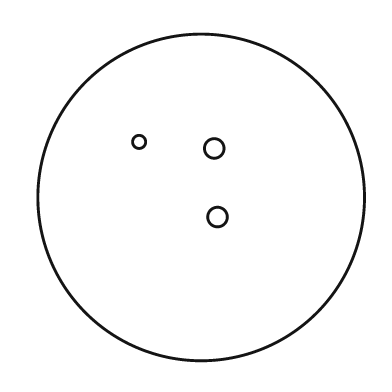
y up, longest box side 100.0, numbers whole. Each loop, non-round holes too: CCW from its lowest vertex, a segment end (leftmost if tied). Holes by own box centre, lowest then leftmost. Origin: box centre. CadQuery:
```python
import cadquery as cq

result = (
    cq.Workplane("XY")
    .moveTo(0.0, 0.0)
    .circle(50.0)
    .moveTo(5.0, -6.0)
    .circle(3.0)
    .moveTo(4.0, 15.0)
    .circle(3.0)
    .moveTo(-19.0, 17.0)
    .circle(2.0)
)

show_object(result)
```